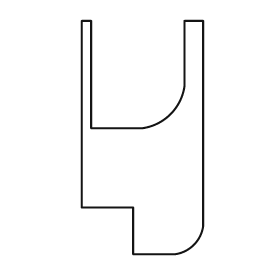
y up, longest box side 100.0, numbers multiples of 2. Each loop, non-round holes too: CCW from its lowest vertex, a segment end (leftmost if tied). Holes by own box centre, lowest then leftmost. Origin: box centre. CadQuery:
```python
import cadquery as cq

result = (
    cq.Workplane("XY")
    .moveTo(-4.0, -50.0)
    .lineTo(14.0, -50.0)
    .threePointArc((22.0, -46.0), (26.0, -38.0))
    .lineTo(26.0, 50.0)
    .lineTo(18.0, 50.0)
    .lineTo(18.0, 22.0)
    .threePointArc((12.0, 10.0), (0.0, 4.0))
    .lineTo(-22.0, 4.0)
    .lineTo(-22.0, 50.0)
    .lineTo(-26.0, 50.0)
    .lineTo(-26.0, -30.0)
    .lineTo(-4.0, -30.0)
    .close()
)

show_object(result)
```